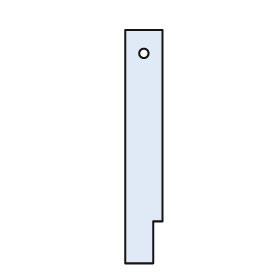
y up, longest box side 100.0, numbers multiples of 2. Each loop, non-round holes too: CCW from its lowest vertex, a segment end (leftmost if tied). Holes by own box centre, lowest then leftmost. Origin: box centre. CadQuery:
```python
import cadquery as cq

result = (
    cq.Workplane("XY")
    .moveTo(-8.0, -50.0)
    .lineTo(4.0, -50.0)
    .lineTo(4.0, -32.0)
    .lineTo(8.0, -32.0)
    .lineTo(8.0, 50.0)
    .lineTo(-8.0, 50.0)
    .close()
    .moveTo(0.0, 40.0)
    .circle(2.0)
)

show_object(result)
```